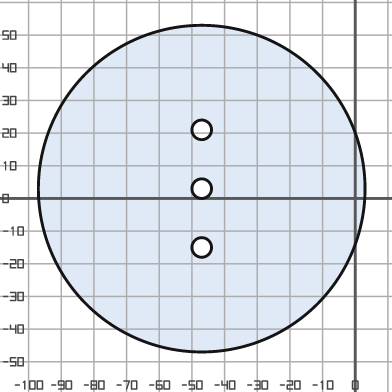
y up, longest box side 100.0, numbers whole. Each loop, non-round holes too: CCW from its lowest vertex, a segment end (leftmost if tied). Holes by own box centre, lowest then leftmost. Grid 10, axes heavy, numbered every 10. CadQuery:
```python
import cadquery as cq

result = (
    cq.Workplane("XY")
    .moveTo(-47.0, 3.0)
    .circle(50.0)
    .moveTo(-47.0, -15.0)
    .circle(3.0)
    .moveTo(-47.0, 3.0)
    .circle(3.0)
    .moveTo(-47.0, 21.0)
    .circle(3.0)
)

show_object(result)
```